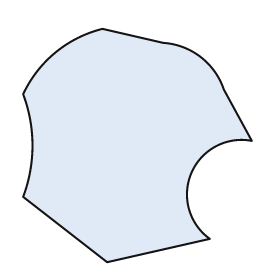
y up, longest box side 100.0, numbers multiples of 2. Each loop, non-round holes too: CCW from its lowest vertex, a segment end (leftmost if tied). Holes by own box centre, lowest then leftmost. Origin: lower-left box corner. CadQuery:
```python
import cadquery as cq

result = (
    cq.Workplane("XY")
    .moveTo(36.0, 0.0)
    .lineTo(80.0, 10.0)
    .threePointArc((72.0, 38.0), (98.0, 52.0))
    .lineTo(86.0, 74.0)
    .threePointArc((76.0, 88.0), (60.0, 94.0))
    .lineTo(34.0, 100.0)
    .threePointArc((14.0, 90.0), (0.0, 72.0))
    .threePointArc((4.0, 50.0), (0.0, 28.0))
    .close()
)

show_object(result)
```